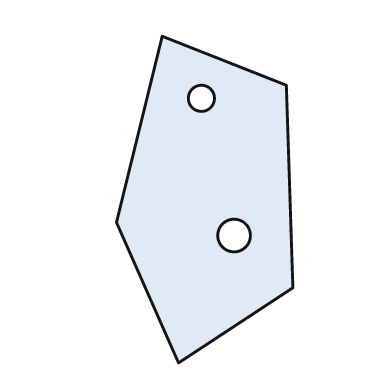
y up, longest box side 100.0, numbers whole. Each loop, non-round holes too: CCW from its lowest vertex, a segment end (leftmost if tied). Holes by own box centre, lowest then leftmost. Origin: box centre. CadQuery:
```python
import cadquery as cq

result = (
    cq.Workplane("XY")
    .moveTo(-8.0, -50.0)
    .lineTo(27.0, -27.0)
    .lineTo(25.0, 35.0)
    .lineTo(-13.0, 50.0)
    .lineTo(-27.0, -7.0)
    .close()
    .moveTo(9.0, -11.0)
    .circle(5.0)
    .moveTo(-1.0, 31.0)
    .circle(4.0)
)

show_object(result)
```